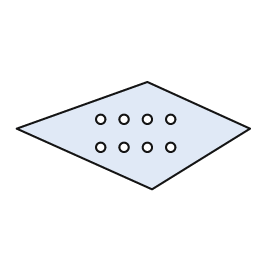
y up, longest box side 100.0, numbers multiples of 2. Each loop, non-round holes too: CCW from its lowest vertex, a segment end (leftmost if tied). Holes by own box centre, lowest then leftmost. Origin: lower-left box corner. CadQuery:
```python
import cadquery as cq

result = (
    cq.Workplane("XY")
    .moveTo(58.0, 0.0)
    .lineTo(100.0, 26.0)
    .lineTo(56.0, 46.0)
    .lineTo(0.0, 26.0)
    .close()
    .moveTo(36.0, 18.0)
    .circle(2.0)
    .moveTo(46.0, 18.0)
    .circle(2.0)
    .moveTo(56.0, 18.0)
    .circle(2.0)
    .moveTo(66.0, 18.0)
    .circle(2.0)
    .moveTo(36.0, 30.0)
    .circle(2.0)
    .moveTo(46.0, 30.0)
    .circle(2.0)
    .moveTo(56.0, 30.0)
    .circle(2.0)
    .moveTo(66.0, 30.0)
    .circle(2.0)
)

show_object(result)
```